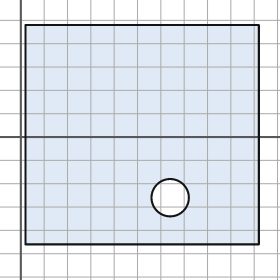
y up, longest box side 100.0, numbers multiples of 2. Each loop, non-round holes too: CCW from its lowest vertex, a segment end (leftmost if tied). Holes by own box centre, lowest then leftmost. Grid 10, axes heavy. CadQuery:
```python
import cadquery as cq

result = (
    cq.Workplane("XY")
    .moveTo(2.0, -46.0)
    .lineTo(102.0, -46.0)
    .lineTo(102.0, 48.0)
    .lineTo(2.0, 48.0)
    .close()
    .moveTo(64.0, -26.0)
    .circle(8.0)
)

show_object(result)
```